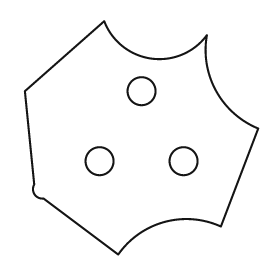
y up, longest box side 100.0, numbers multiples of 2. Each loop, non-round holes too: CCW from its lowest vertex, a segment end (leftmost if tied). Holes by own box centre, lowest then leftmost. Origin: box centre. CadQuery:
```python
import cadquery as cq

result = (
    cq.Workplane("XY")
    .moveTo(-10.0, -50.0)
    .threePointArc((10.0, -36.0), (34.0, -38.0))
    .lineTo(50.0, 4.0)
    .threePointArc((32.0, 20.0), (28.0, 44.0))
    .threePointArc((4.0, 34.0), (-16.0, 50.0))
    .lineTo(-50.0, 20.0)
    .lineTo(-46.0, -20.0)
    .threePointArc((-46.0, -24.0), (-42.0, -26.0))
    .close()
    .moveTo(-18.0, -10.0)
    .circle(6.0)
    .moveTo(18.0, -10.0)
    .circle(6.0)
    .moveTo(0.0, 20.0)
    .circle(6.0)
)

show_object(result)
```